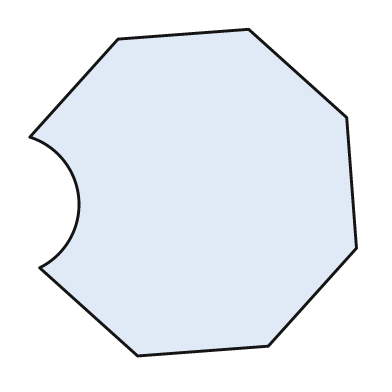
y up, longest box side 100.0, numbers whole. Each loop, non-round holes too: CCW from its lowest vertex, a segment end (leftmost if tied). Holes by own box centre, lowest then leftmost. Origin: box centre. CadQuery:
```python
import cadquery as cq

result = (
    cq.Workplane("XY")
    .moveTo(-17.0, -50.0)
    .lineTo(23.0, -47.0)
    .lineTo(50.0, -17.0)
    .lineTo(47.0, 23.0)
    .lineTo(17.0, 50.0)
    .lineTo(-23.0, 47.0)
    .lineTo(-50.0, 17.0)
    .threePointArc((-35.0, -2.0), (-47.0, -23.0))
    .close()
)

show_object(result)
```